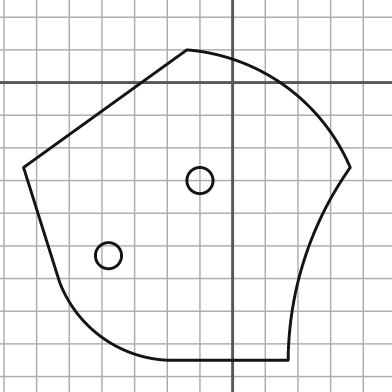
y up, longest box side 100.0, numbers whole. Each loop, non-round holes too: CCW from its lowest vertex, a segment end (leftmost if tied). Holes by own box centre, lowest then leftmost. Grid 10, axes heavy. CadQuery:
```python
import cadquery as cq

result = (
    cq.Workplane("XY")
    .moveTo(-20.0, -85.0)
    .lineTo(17.0, -85.0)
    .threePointArc((22.0, -54.0), (36.0, -26.0))
    .threePointArc((16.0, -1.0), (-14.0, 10.0))
    .lineTo(-64.0, -26.0)
    .lineTo(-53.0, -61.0)
    .threePointArc((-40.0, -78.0), (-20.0, -85.0))
    .close()
    .moveTo(-38.0, -53.0)
    .circle(4.0)
    .moveTo(-10.0, -30.0)
    .circle(4.0)
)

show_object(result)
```